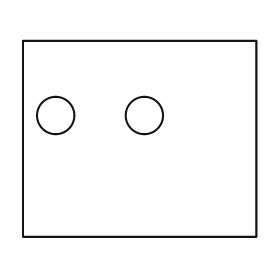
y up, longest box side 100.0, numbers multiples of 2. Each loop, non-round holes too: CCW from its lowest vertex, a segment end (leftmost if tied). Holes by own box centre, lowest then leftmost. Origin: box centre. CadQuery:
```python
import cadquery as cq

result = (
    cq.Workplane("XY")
    .moveTo(-50.0, -42.0)
    .lineTo(50.0, -42.0)
    .lineTo(50.0, 42.0)
    .lineTo(-50.0, 42.0)
    .close()
    .moveTo(-36.0, 10.0)
    .circle(8.0)
    .moveTo(2.0, 10.0)
    .circle(8.0)
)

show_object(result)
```